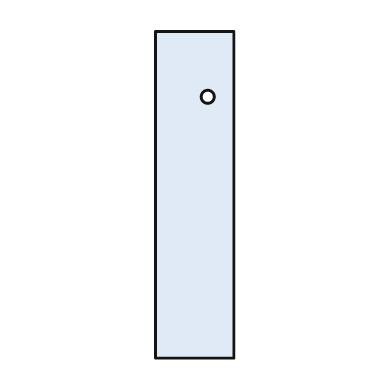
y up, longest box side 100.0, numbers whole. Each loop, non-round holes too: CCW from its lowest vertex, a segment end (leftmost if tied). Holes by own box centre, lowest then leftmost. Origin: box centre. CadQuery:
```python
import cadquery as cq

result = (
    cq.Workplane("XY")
    .moveTo(-12.0, -50.0)
    .lineTo(12.0, -50.0)
    .lineTo(12.0, 50.0)
    .lineTo(-12.0, 50.0)
    .close()
    .moveTo(4.0, 30.0)
    .circle(2.0)
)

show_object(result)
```